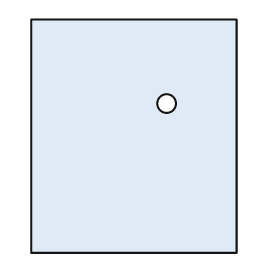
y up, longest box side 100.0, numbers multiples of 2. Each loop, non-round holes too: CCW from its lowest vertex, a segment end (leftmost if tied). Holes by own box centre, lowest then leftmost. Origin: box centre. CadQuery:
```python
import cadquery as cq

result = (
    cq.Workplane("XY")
    .moveTo(-44.0, -50.0)
    .lineTo(44.0, -50.0)
    .lineTo(44.0, 50.0)
    .lineTo(-44.0, 50.0)
    .close()
    .moveTo(14.0, 14.0)
    .circle(4.0)
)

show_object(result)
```